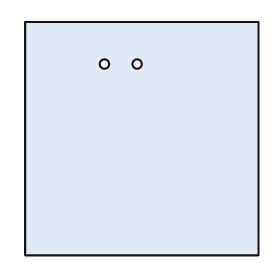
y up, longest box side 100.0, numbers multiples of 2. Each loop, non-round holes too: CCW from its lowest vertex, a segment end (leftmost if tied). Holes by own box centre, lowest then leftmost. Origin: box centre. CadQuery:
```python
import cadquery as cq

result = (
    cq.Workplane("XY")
    .moveTo(-50.0, -50.0)
    .lineTo(50.0, -50.0)
    .lineTo(50.0, 50.0)
    .lineTo(-50.0, 50.0)
    .close()
    .moveTo(-16.0, 32.0)
    .circle(2.0)
    .moveTo(-2.0, 32.0)
    .circle(2.0)
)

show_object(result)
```